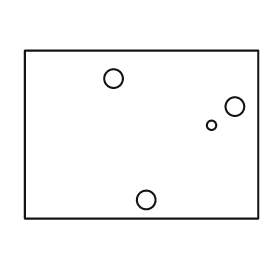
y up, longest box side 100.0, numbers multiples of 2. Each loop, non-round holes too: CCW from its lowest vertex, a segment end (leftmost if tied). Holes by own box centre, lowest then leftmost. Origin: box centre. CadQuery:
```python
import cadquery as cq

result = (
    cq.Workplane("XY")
    .moveTo(-50.0, -36.0)
    .lineTo(50.0, -36.0)
    .lineTo(50.0, 36.0)
    .lineTo(-50.0, 36.0)
    .close()
    .moveTo(2.0, -28.0)
    .circle(4.0)
    .moveTo(30.0, 4.0)
    .circle(2.0)
    .moveTo(40.0, 12.0)
    .circle(4.0)
    .moveTo(-12.0, 24.0)
    .circle(4.0)
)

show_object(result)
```